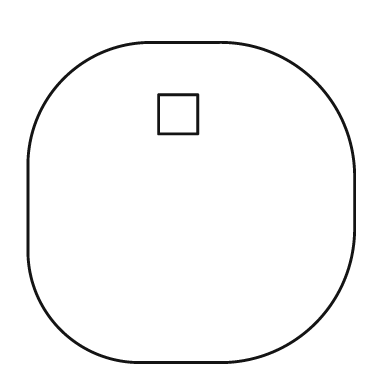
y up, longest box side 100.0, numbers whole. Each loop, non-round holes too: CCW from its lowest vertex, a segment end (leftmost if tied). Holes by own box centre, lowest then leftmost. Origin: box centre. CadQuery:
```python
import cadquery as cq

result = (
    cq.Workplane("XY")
    .moveTo(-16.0, -49.0)
    .lineTo(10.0, -49.0)
    .threePointArc((38.0, -37.0), (50.0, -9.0))
    .lineTo(50.0, 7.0)
    .threePointArc((38.0, 37.0), (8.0, 49.0))
    .lineTo(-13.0, 49.0)
    .threePointArc((-39.0, 38.0), (-50.0, 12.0))
    .lineTo(-50.0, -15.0)
    .threePointArc((-40.0, -39.0), (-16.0, -49.0))
    .close()
    .moveTo(-10.0, 21.0)
    .lineTo(2.0, 21.0)
    .lineTo(2.0, 33.0)
    .lineTo(-10.0, 33.0)
    .close()
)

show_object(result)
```